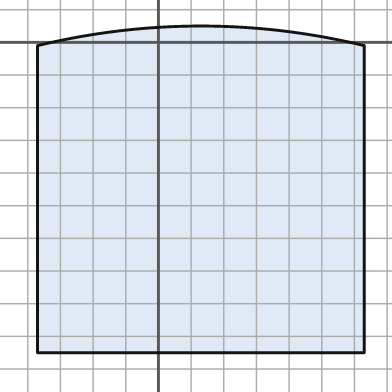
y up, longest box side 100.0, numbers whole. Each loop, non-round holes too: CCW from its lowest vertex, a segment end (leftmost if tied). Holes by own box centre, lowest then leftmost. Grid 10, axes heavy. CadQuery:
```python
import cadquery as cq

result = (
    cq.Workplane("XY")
    .moveTo(-37.0, -95.0)
    .lineTo(63.0, -95.0)
    .lineTo(63.0, -1.0)
    .threePointArc((13.0, 5.0), (-37.0, -1.0))
    .close()
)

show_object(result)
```